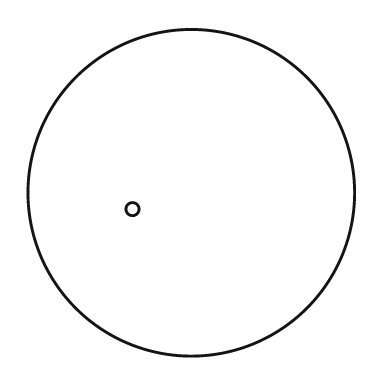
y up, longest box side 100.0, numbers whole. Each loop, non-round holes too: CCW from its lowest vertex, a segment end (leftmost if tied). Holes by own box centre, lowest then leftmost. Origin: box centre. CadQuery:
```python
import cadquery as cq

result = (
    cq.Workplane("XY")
    .moveTo(0.0, 0.0)
    .circle(50.0)
    .moveTo(-18.0, -5.0)
    .circle(2.0)
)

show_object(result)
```